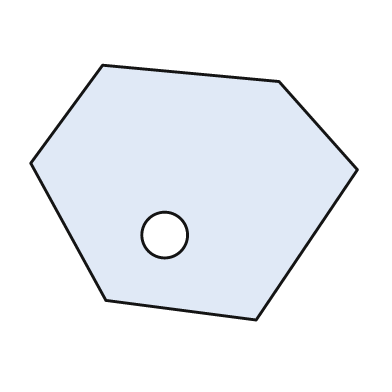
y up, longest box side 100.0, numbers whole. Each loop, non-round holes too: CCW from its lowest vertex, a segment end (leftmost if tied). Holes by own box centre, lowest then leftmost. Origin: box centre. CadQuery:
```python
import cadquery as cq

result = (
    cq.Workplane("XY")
    .moveTo(19.0, -39.0)
    .lineTo(50.0, 7.0)
    .lineTo(26.0, 34.0)
    .lineTo(-28.0, 39.0)
    .lineTo(-50.0, 9.0)
    .lineTo(-27.0, -33.0)
    .close()
    .moveTo(-9.0, -13.0)
    .circle(7.0)
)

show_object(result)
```